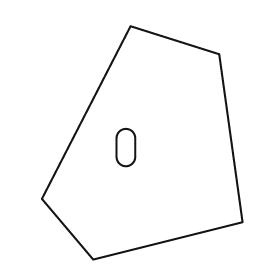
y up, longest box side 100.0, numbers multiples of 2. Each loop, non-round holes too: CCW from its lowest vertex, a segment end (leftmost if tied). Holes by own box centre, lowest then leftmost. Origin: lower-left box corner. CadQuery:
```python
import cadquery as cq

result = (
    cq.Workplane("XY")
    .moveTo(22.0, 0.0)
    .lineTo(86.0, 16.0)
    .lineTo(76.0, 88.0)
    .lineTo(38.0, 100.0)
    .lineTo(0.0, 26.0)
    .close()
    .moveTo(32.0, 44.0)
    .threePointArc((36.0, 40.0), (40.0, 44.0))
    .lineTo(40.0, 52.0)
    .threePointArc((36.0, 56.0), (32.0, 52.0))
    .close()
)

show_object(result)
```